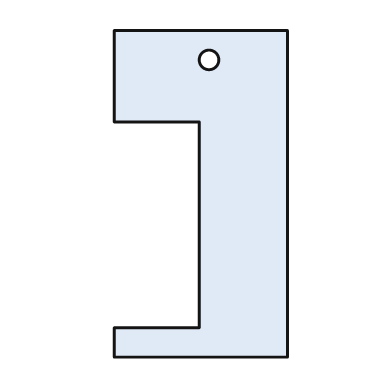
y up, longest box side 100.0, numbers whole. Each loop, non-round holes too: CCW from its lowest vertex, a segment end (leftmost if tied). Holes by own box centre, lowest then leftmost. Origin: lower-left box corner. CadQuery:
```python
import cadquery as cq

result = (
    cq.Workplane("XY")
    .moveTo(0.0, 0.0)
    .lineTo(53.0, 0.0)
    .lineTo(53.0, 100.0)
    .lineTo(0.0, 100.0)
    .lineTo(0.0, 72.0)
    .lineTo(26.0, 72.0)
    .lineTo(26.0, 9.0)
    .lineTo(0.0, 9.0)
    .close()
    .moveTo(29.0, 91.0)
    .circle(3.0)
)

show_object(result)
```